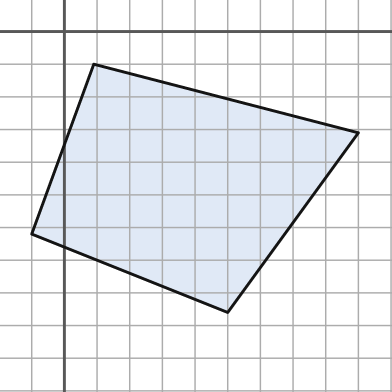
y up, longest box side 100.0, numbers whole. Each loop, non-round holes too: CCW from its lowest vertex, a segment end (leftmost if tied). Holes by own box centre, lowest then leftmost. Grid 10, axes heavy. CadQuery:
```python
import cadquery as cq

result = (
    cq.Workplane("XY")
    .moveTo(50.0, -86.0)
    .lineTo(90.0, -31.0)
    .lineTo(9.0, -10.0)
    .lineTo(-10.0, -62.0)
    .close()
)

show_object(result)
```